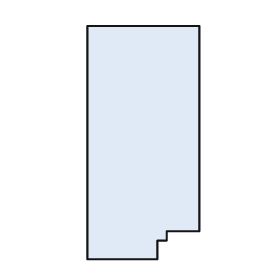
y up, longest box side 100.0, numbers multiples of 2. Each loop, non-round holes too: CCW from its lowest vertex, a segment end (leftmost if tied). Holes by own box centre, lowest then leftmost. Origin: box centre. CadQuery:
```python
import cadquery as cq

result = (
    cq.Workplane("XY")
    .moveTo(-24.0, -50.0)
    .lineTo(6.0, -50.0)
    .lineTo(6.0, -42.0)
    .lineTo(10.0, -42.0)
    .lineTo(10.0, -38.0)
    .lineTo(24.0, -38.0)
    .lineTo(24.0, 50.0)
    .lineTo(-24.0, 50.0)
    .close()
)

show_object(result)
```